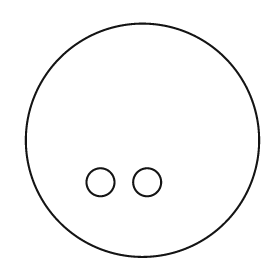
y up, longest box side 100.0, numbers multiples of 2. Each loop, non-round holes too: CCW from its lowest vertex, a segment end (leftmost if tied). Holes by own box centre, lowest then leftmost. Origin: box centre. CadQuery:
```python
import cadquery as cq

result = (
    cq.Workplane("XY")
    .moveTo(0.0, 0.0)
    .circle(50.0)
    .moveTo(-18.0, -18.0)
    .circle(6.0)
    .moveTo(2.0, -18.0)
    .circle(6.0)
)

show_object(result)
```